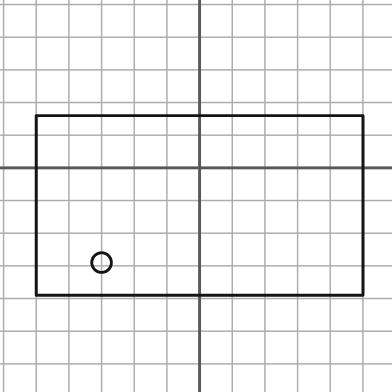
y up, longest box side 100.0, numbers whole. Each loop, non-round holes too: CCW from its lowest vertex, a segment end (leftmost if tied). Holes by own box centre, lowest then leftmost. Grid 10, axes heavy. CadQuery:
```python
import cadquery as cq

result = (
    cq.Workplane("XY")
    .moveTo(-50.0, -39.0)
    .lineTo(50.0, -39.0)
    .lineTo(50.0, 16.0)
    .lineTo(-50.0, 16.0)
    .close()
    .moveTo(-30.0, -29.0)
    .circle(3.0)
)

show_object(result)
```